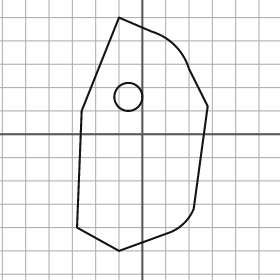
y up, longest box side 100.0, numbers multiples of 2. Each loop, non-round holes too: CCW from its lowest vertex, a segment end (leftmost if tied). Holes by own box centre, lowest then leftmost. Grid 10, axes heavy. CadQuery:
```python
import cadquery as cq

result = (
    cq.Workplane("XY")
    .moveTo(-10.0, -50.0)
    .lineTo(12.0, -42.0)
    .threePointArc((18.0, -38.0), (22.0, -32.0))
    .lineTo(28.0, 12.0)
    .lineTo(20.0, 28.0)
    .threePointArc((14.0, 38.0), (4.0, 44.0))
    .lineTo(-10.0, 50.0)
    .lineTo(-26.0, 10.0)
    .lineTo(-28.0, -40.0)
    .close()
    .moveTo(-6.0, 16.0)
    .circle(6.0)
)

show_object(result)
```